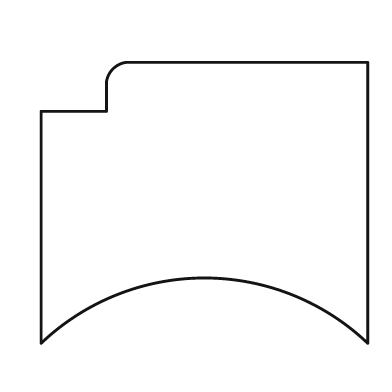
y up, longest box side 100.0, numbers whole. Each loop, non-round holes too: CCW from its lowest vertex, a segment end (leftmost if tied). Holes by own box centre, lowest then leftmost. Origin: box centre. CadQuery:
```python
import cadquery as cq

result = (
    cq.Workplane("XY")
    .moveTo(-50.0, -43.0)
    .threePointArc((0.0, -23.0), (50.0, -43.0))
    .lineTo(50.0, 43.0)
    .lineTo(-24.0, 43.0)
    .threePointArc((-28.0, 41.0), (-30.0, 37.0))
    .lineTo(-30.0, 28.0)
    .lineTo(-50.0, 28.0)
    .close()
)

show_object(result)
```